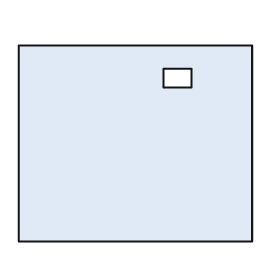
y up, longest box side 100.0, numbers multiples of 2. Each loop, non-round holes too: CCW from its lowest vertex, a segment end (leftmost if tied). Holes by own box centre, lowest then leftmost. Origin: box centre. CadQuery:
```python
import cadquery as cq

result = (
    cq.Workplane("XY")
    .moveTo(-50.0, -42.0)
    .lineTo(50.0, -42.0)
    .lineTo(50.0, 42.0)
    .lineTo(-50.0, 42.0)
    .close()
    .moveTo(12.0, 24.0)
    .lineTo(24.0, 24.0)
    .lineTo(24.0, 32.0)
    .lineTo(12.0, 32.0)
    .close()
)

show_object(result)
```